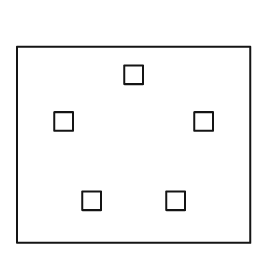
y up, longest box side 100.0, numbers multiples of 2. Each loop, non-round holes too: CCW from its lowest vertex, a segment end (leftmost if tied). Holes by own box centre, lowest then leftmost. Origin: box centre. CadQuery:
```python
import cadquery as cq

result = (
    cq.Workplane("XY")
    .moveTo(-50.0, -42.0)
    .lineTo(50.0, -42.0)
    .lineTo(50.0, 42.0)
    .lineTo(-50.0, 42.0)
    .close()
    .moveTo(-22.0, -28.0)
    .lineTo(-14.0, -28.0)
    .lineTo(-14.0, -20.0)
    .lineTo(-22.0, -20.0)
    .close()
    .moveTo(14.0, -28.0)
    .lineTo(22.0, -28.0)
    .lineTo(22.0, -20.0)
    .lineTo(14.0, -20.0)
    .close()
    .moveTo(-34.0, 6.0)
    .lineTo(-26.0, 6.0)
    .lineTo(-26.0, 14.0)
    .lineTo(-34.0, 14.0)
    .close()
    .moveTo(26.0, 6.0)
    .lineTo(34.0, 6.0)
    .lineTo(34.0, 14.0)
    .lineTo(26.0, 14.0)
    .close()
    .moveTo(-4.0, 26.0)
    .lineTo(4.0, 26.0)
    .lineTo(4.0, 34.0)
    .lineTo(-4.0, 34.0)
    .close()
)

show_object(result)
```